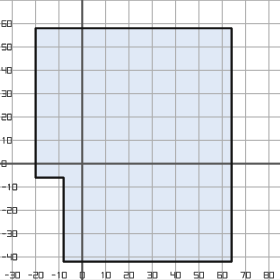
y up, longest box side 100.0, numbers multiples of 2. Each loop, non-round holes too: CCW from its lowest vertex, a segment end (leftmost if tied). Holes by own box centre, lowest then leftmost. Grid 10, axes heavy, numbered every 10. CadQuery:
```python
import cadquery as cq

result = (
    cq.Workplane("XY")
    .moveTo(-8.0, -42.0)
    .lineTo(64.0, -42.0)
    .lineTo(64.0, 58.0)
    .lineTo(-20.0, 58.0)
    .lineTo(-20.0, -6.0)
    .lineTo(-8.0, -6.0)
    .close()
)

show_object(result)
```